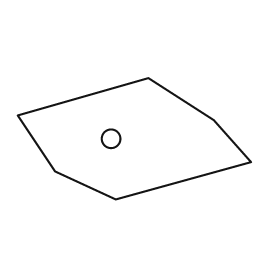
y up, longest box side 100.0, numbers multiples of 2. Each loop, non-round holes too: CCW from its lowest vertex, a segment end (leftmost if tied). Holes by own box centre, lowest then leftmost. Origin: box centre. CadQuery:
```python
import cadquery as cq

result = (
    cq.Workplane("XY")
    .moveTo(-8.0, -26.0)
    .lineTo(50.0, -10.0)
    .lineTo(34.0, 8.0)
    .lineTo(6.0, 26.0)
    .lineTo(-50.0, 10.0)
    .lineTo(-34.0, -14.0)
    .close()
    .moveTo(-10.0, 0.0)
    .circle(4.0)
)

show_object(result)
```